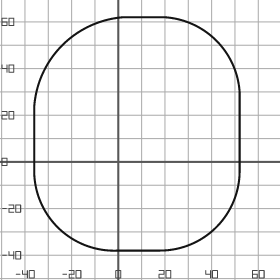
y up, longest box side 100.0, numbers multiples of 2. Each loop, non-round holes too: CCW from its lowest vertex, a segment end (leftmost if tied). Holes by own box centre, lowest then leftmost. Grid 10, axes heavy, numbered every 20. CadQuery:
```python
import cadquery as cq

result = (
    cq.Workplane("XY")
    .moveTo(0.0, -38.0)
    .lineTo(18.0, -38.0)
    .threePointArc((42.0, -28.0), (52.0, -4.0))
    .lineTo(52.0, 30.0)
    .threePointArc((42.0, 52.0), (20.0, 62.0))
    .lineTo(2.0, 62.0)
    .threePointArc((-24.0, 50.0), (-36.0, 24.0))
    .lineTo(-36.0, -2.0)
    .threePointArc((-26.0, -28.0), (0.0, -38.0))
    .close()
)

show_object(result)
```